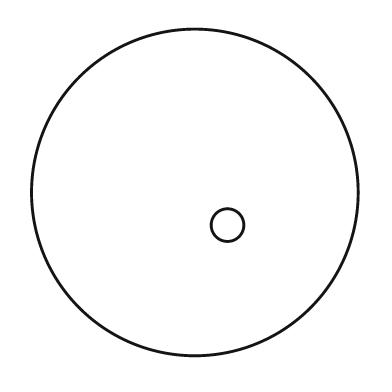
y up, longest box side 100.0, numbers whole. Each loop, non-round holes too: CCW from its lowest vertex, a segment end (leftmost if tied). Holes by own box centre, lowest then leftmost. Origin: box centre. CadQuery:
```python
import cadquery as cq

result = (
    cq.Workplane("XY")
    .moveTo(0.0, 0.0)
    .circle(50.0)
    .moveTo(10.0, -10.0)
    .circle(5.0)
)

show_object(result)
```